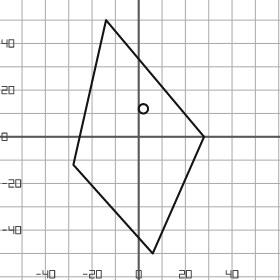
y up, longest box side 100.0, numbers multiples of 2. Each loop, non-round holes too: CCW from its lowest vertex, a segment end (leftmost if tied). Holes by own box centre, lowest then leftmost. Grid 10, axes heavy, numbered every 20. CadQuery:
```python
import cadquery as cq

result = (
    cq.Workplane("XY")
    .moveTo(6.0, -50.0)
    .lineTo(28.0, 0.0)
    .lineTo(-14.0, 50.0)
    .lineTo(-28.0, -12.0)
    .close()
    .moveTo(2.0, 12.0)
    .circle(2.0)
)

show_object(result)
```